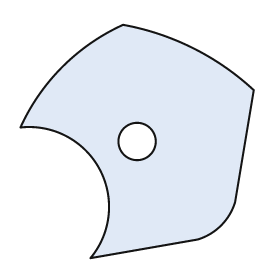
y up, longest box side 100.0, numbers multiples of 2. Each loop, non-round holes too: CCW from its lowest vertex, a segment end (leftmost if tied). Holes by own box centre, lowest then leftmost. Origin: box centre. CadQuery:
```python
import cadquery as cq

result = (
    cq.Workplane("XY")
    .moveTo(-20.0, -50.0)
    .lineTo(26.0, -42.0)
    .threePointArc((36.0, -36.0), (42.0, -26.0))
    .lineTo(50.0, 22.0)
    .threePointArc((24.0, 40.0), (-6.0, 50.0))
    .threePointArc((-32.0, 32.0), (-50.0, 6.0))
    .threePointArc((-16.0, -12.0), (-20.0, -50.0))
    .close()
    .moveTo(0.0, 0.0)
    .circle(8.0)
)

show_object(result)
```